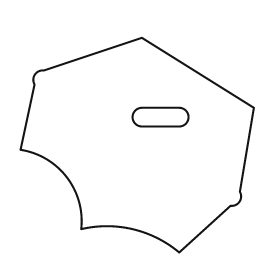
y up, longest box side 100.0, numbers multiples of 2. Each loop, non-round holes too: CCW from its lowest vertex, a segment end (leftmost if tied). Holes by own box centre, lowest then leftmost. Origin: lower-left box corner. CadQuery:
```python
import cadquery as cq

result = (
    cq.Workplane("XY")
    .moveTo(68.0, 0.0)
    .lineTo(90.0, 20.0)
    .threePointArc((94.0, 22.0), (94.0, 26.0))
    .lineTo(100.0, 62.0)
    .lineTo(52.0, 92.0)
    .lineTo(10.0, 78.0)
    .threePointArc((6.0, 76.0), (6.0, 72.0))
    .lineTo(0.0, 44.0)
    .threePointArc((20.0, 32.0), (26.0, 10.0))
    .threePointArc((48.0, 10.0), (68.0, 0.0))
    .close()
    .moveTo(52.0, 54.0)
    .lineTo(68.0, 54.0)
    .threePointArc((72.0, 58.0), (68.0, 62.0))
    .lineTo(52.0, 62.0)
    .threePointArc((48.0, 58.0), (52.0, 54.0))
    .close()
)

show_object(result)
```